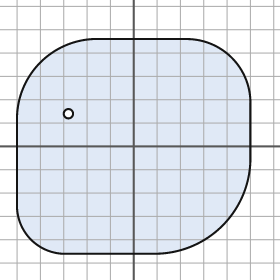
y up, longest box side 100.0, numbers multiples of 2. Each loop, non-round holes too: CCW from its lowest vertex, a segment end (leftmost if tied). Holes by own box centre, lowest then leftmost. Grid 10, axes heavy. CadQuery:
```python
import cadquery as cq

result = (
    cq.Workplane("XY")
    .moveTo(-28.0, -46.0)
    .lineTo(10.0, -46.0)
    .threePointArc((38.0, -34.0), (50.0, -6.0))
    .lineTo(50.0, 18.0)
    .threePointArc((42.0, 38.0), (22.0, 46.0))
    .lineTo(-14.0, 46.0)
    .threePointArc((-40.0, 36.0), (-50.0, 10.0))
    .lineTo(-50.0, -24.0)
    .threePointArc((-44.0, -40.0), (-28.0, -46.0))
    .close()
    .moveTo(-28.0, 14.0)
    .circle(2.0)
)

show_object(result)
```